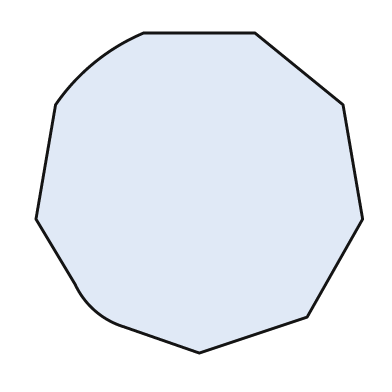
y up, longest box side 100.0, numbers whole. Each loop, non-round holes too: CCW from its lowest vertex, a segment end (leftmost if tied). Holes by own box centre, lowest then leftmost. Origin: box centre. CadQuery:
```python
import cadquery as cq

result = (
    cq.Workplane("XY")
    .moveTo(0.0, -49.0)
    .lineTo(33.0, -38.0)
    .lineTo(50.0, -8.0)
    .lineTo(44.0, 27.0)
    .lineTo(17.0, 49.0)
    .lineTo(-17.0, 49.0)
    .threePointArc((-32.0, 40.0), (-44.0, 27.0))
    .lineTo(-50.0, -8.0)
    .lineTo(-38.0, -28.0)
    .threePointArc((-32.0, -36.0), (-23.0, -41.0))
    .close()
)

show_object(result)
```